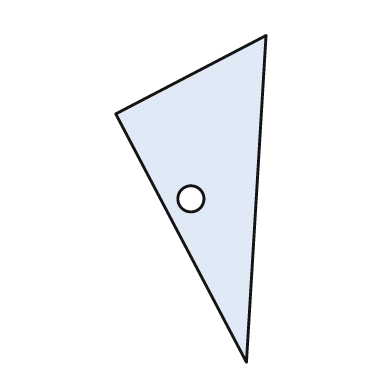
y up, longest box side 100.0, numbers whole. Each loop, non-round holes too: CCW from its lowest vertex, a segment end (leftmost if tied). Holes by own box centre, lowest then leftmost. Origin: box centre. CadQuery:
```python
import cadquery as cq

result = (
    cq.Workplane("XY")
    .moveTo(17.0, -50.0)
    .lineTo(23.0, 50.0)
    .lineTo(-23.0, 26.0)
    .close()
    .moveTo(0.0, 0.0)
    .circle(4.0)
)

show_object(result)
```